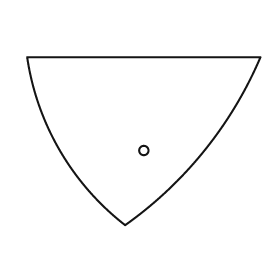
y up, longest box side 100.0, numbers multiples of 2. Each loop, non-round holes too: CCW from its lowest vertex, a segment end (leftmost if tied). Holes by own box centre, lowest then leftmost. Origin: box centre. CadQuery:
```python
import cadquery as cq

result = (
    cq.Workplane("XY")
    .moveTo(-8.0, -36.0)
    .threePointArc((26.0, -4.0), (50.0, 36.0))
    .lineTo(-50.0, 36.0)
    .threePointArc((-36.0, -4.0), (-8.0, -36.0))
    .close()
    .moveTo(0.0, -4.0)
    .circle(2.0)
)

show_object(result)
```